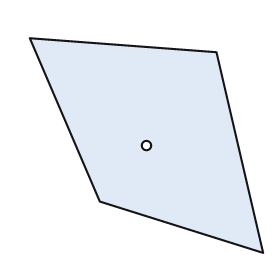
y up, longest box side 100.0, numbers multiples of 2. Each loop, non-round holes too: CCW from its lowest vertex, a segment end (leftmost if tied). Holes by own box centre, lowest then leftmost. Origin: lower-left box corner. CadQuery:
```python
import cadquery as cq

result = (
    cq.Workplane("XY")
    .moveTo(100.0, 0.0)
    .lineTo(80.0, 86.0)
    .lineTo(0.0, 92.0)
    .lineTo(30.0, 22.0)
    .close()
    .moveTo(50.0, 46.0)
    .circle(2.0)
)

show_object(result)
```